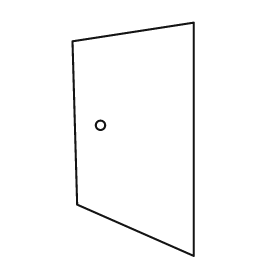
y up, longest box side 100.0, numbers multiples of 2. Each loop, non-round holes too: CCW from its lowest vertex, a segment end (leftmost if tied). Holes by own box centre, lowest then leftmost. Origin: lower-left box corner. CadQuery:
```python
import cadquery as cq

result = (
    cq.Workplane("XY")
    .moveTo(52.0, 0.0)
    .lineTo(52.0, 100.0)
    .lineTo(0.0, 92.0)
    .lineTo(2.0, 22.0)
    .close()
    .moveTo(12.0, 56.0)
    .circle(2.0)
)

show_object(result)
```